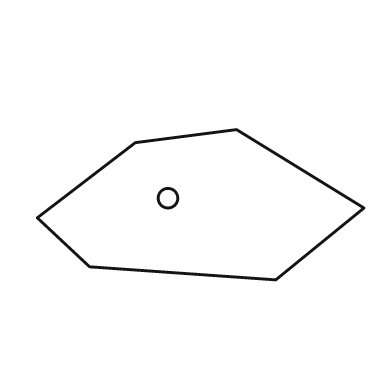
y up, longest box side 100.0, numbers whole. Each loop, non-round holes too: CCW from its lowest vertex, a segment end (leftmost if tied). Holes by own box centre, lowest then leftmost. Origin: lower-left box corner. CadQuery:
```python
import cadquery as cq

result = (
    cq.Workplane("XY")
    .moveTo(73.0, 0.0)
    .lineTo(100.0, 22.0)
    .lineTo(61.0, 46.0)
    .lineTo(30.0, 42.0)
    .lineTo(0.0, 19.0)
    .lineTo(16.0, 4.0)
    .close()
    .moveTo(40.0, 25.0)
    .circle(3.0)
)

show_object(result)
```